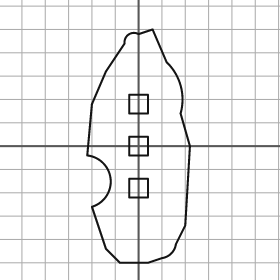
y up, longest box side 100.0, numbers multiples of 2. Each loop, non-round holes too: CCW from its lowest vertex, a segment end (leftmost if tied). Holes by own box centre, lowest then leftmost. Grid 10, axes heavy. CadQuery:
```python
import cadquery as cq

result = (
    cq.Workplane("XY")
    .moveTo(-8.0, -50.0)
    .lineTo(4.0, -50.0)
    .lineTo(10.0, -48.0)
    .threePointArc((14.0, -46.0), (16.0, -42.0))
    .lineTo(20.0, -34.0)
    .lineTo(22.0, 0.0)
    .lineTo(18.0, 14.0)
    .threePointArc((18.0, 26.0), (12.0, 36.0))
    .lineTo(6.0, 50.0)
    .lineTo(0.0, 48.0)
    .threePointArc((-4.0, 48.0), (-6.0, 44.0))
    .lineTo(-14.0, 32.0)
    .lineTo(-20.0, 18.0)
    .lineTo(-22.0, -4.0)
    .threePointArc((-12.0, -14.0), (-20.0, -26.0))
    .lineTo(-14.0, -44.0)
    .close()
    .moveTo(-4.0, -22.0)
    .lineTo(4.0, -22.0)
    .lineTo(4.0, -14.0)
    .lineTo(-4.0, -14.0)
    .close()
    .moveTo(-4.0, -4.0)
    .lineTo(4.0, -4.0)
    .lineTo(4.0, 4.0)
    .lineTo(-4.0, 4.0)
    .close()
    .moveTo(-4.0, 14.0)
    .lineTo(4.0, 14.0)
    .lineTo(4.0, 22.0)
    .lineTo(-4.0, 22.0)
    .close()
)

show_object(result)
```